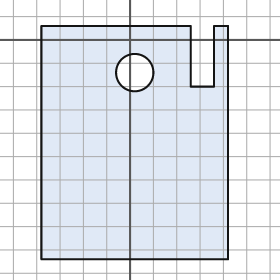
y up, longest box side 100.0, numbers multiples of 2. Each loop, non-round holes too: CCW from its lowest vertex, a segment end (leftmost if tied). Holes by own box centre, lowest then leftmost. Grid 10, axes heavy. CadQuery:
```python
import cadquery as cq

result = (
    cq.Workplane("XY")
    .moveTo(-38.0, -94.0)
    .lineTo(42.0, -94.0)
    .lineTo(42.0, 6.0)
    .lineTo(36.0, 6.0)
    .lineTo(36.0, -20.0)
    .lineTo(26.0, -20.0)
    .lineTo(26.0, 6.0)
    .lineTo(-38.0, 6.0)
    .close()
    .moveTo(2.0, -14.0)
    .circle(8.0)
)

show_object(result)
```